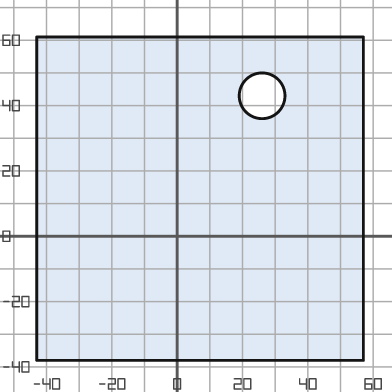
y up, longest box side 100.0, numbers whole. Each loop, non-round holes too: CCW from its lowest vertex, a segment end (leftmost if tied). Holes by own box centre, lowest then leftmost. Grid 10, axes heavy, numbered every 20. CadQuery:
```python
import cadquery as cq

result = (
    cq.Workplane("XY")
    .moveTo(-43.0, -38.0)
    .lineTo(57.0, -38.0)
    .lineTo(57.0, 61.0)
    .lineTo(-43.0, 61.0)
    .close()
    .moveTo(26.0, 43.0)
    .circle(7.0)
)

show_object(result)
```